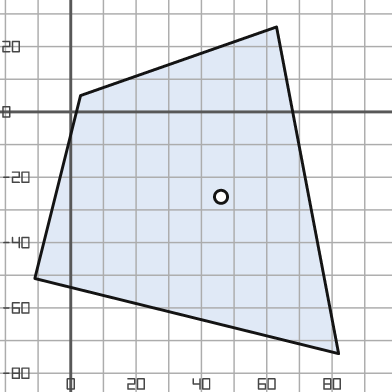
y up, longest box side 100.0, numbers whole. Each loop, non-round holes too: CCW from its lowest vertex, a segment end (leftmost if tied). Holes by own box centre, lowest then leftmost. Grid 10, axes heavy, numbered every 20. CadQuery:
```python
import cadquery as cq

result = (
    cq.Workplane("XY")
    .moveTo(82.0, -74.0)
    .lineTo(63.0, 26.0)
    .lineTo(3.0, 5.0)
    .lineTo(-11.0, -51.0)
    .close()
    .moveTo(46.0, -26.0)
    .circle(2.0)
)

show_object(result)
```